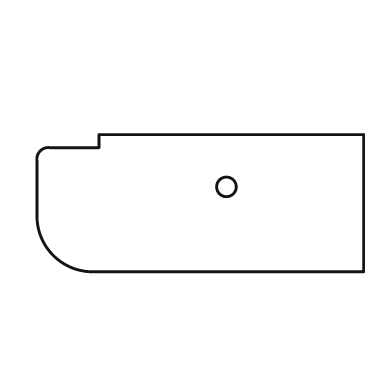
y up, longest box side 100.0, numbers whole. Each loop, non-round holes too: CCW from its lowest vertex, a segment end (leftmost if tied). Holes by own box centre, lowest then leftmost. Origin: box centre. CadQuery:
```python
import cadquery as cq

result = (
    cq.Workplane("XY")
    .moveTo(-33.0, -21.0)
    .lineTo(50.0, -21.0)
    .lineTo(50.0, 21.0)
    .lineTo(-31.0, 21.0)
    .lineTo(-31.0, 17.0)
    .lineTo(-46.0, 17.0)
    .threePointArc((-49.0, 16.0), (-50.0, 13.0))
    .lineTo(-50.0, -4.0)
    .threePointArc((-45.0, -16.0), (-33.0, -21.0))
    .close()
    .moveTo(8.0, 5.0)
    .circle(3.0)
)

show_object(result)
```